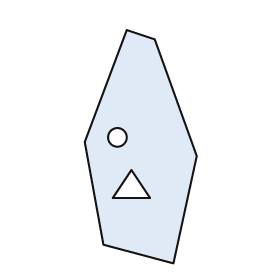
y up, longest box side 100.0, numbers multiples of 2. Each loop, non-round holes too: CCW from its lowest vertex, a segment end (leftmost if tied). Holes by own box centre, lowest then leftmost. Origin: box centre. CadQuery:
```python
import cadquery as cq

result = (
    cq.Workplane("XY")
    .moveTo(14.0, -50.0)
    .lineTo(24.0, -4.0)
    .lineTo(6.0, 46.0)
    .lineTo(-6.0, 50.0)
    .lineTo(-24.0, 2.0)
    .lineTo(-16.0, -42.0)
    .close()
    .moveTo(-12.0, -22.0)
    .lineTo(4.0, -22.0)
    .lineTo(-4.0, -10.0)
    .close()
    .moveTo(-10.0, 4.0)
    .circle(4.0)
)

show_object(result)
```